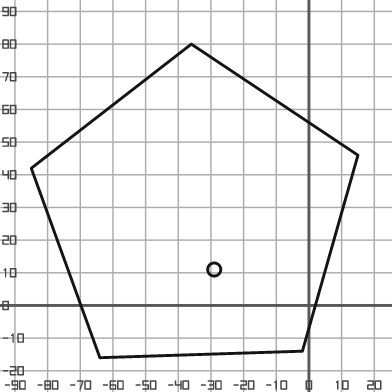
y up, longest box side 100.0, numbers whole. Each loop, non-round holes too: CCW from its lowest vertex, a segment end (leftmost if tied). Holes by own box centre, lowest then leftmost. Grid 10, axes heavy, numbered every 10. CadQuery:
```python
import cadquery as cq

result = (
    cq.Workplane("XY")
    .moveTo(-64.0, -16.0)
    .lineTo(-2.0, -14.0)
    .lineTo(15.0, 46.0)
    .lineTo(-36.0, 80.0)
    .lineTo(-85.0, 42.0)
    .close()
    .moveTo(-29.0, 11.0)
    .circle(2.0)
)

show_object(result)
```